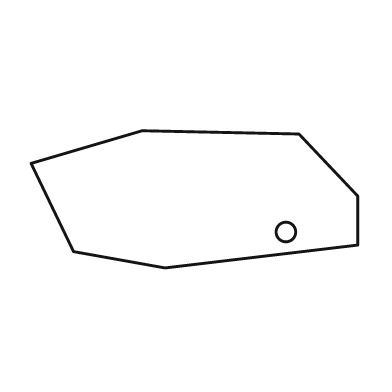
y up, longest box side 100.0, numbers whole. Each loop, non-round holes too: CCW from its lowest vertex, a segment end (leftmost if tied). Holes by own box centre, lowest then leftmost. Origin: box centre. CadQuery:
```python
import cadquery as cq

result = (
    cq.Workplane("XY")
    .moveTo(-9.0, -21.0)
    .lineTo(50.0, -14.0)
    .lineTo(50.0, 1.0)
    .lineTo(32.0, 20.0)
    .lineTo(-16.0, 21.0)
    .lineTo(-50.0, 11.0)
    .lineTo(-37.0, -16.0)
    .close()
    .moveTo(28.0, -10.0)
    .circle(3.0)
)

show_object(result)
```